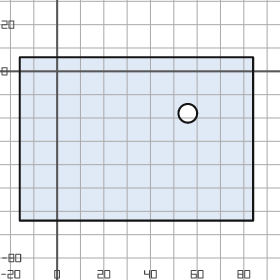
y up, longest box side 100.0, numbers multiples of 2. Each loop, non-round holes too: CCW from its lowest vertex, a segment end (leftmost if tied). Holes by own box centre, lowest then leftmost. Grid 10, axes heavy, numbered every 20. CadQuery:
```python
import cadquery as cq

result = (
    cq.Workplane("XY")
    .moveTo(-16.0, -64.0)
    .lineTo(84.0, -64.0)
    .lineTo(84.0, 6.0)
    .lineTo(-16.0, 6.0)
    .close()
    .moveTo(56.0, -18.0)
    .circle(4.0)
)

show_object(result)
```